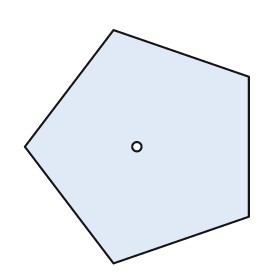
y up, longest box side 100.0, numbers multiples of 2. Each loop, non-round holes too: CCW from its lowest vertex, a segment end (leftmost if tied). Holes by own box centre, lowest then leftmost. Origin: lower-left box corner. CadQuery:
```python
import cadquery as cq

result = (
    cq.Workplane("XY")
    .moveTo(38.0, 0.0)
    .lineTo(96.0, 20.0)
    .lineTo(96.0, 80.0)
    .lineTo(38.0, 100.0)
    .lineTo(0.0, 50.0)
    .close()
    .moveTo(48.0, 50.0)
    .circle(2.0)
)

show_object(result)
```